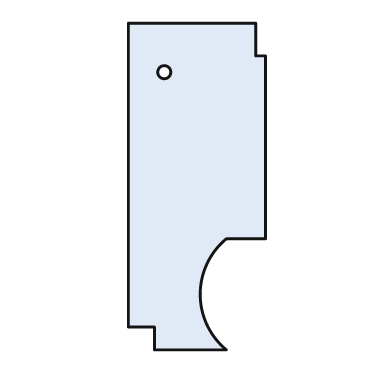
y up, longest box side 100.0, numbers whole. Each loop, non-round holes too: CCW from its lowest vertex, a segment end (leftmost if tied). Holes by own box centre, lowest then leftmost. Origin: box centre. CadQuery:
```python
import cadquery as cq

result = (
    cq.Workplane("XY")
    .moveTo(-13.0, -50.0)
    .lineTo(9.0, -50.0)
    .threePointArc((1.0, -33.0), (9.0, -16.0))
    .lineTo(21.0, -16.0)
    .lineTo(21.0, 40.0)
    .lineTo(18.0, 40.0)
    .lineTo(18.0, 50.0)
    .lineTo(-21.0, 50.0)
    .lineTo(-21.0, -43.0)
    .lineTo(-13.0, -43.0)
    .close()
    .moveTo(-10.0, 35.0)
    .circle(2.0)
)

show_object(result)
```